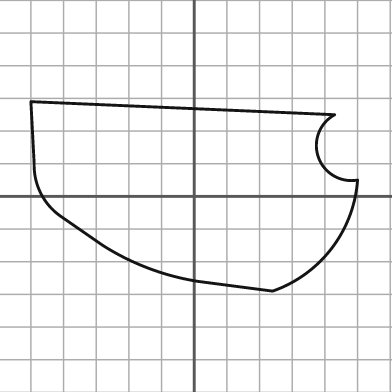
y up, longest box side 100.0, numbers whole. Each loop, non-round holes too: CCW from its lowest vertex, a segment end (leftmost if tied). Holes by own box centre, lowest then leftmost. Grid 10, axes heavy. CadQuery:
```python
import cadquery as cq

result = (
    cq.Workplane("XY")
    .moveTo(24.0, -29.0)
    .threePointArc((42.0, -16.0), (50.0, 5.0))
    .threePointArc((38.0, 12.0), (43.0, 25.0))
    .lineTo(-50.0, 29.0)
    .lineTo(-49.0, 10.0)
    .threePointArc((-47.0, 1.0), (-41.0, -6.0))
    .lineTo(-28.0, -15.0)
    .threePointArc((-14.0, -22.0), (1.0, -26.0))
    .close()
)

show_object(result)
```